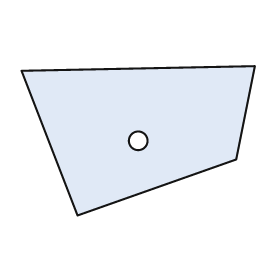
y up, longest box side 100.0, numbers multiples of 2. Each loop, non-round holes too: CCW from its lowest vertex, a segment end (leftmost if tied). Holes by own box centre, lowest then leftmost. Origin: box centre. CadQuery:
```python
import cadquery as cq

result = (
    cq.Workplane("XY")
    .moveTo(-26.0, -32.0)
    .lineTo(42.0, -8.0)
    .lineTo(50.0, 32.0)
    .lineTo(-50.0, 30.0)
    .close()
    .moveTo(0.0, 0.0)
    .circle(4.0)
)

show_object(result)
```